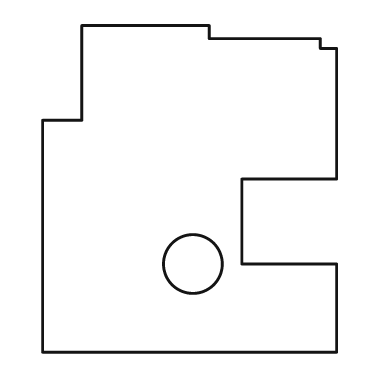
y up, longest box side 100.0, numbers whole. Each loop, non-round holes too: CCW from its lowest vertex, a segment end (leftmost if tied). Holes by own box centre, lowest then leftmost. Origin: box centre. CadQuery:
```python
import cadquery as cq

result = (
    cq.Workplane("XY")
    .moveTo(-45.0, -50.0)
    .lineTo(45.0, -50.0)
    .lineTo(45.0, -23.0)
    .lineTo(16.0, -23.0)
    .lineTo(16.0, 3.0)
    .lineTo(45.0, 3.0)
    .lineTo(45.0, 43.0)
    .lineTo(40.0, 43.0)
    .lineTo(40.0, 46.0)
    .lineTo(6.0, 46.0)
    .lineTo(6.0, 50.0)
    .lineTo(-33.0, 50.0)
    .lineTo(-33.0, 21.0)
    .lineTo(-45.0, 21.0)
    .close()
    .moveTo(1.0, -23.0)
    .circle(9.0)
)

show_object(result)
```